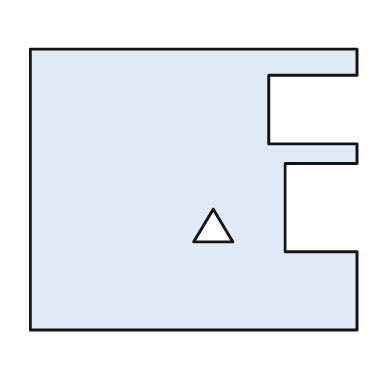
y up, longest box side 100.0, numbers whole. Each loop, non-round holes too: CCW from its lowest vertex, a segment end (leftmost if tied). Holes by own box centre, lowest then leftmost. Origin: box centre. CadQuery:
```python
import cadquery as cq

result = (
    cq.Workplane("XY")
    .moveTo(-50.0, -43.0)
    .lineTo(50.0, -43.0)
    .lineTo(50.0, -19.0)
    .lineTo(28.0, -19.0)
    .lineTo(28.0, 8.0)
    .lineTo(50.0, 8.0)
    .lineTo(50.0, 14.0)
    .lineTo(23.0, 14.0)
    .lineTo(23.0, 35.0)
    .lineTo(50.0, 35.0)
    .lineTo(50.0, 43.0)
    .lineTo(-50.0, 43.0)
    .close()
    .moveTo(0.0, -16.0)
    .lineTo(12.0, -16.0)
    .lineTo(6.0, -6.0)
    .close()
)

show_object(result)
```